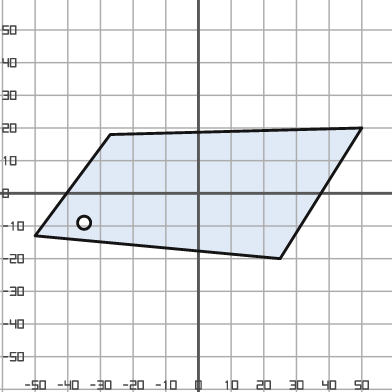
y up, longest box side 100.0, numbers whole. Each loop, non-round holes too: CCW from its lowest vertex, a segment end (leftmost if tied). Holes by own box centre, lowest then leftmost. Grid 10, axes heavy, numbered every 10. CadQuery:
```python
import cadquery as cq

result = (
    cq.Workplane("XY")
    .moveTo(25.0, -20.0)
    .lineTo(50.0, 20.0)
    .lineTo(-27.0, 18.0)
    .lineTo(-50.0, -13.0)
    .close()
    .moveTo(-35.0, -9.0)
    .circle(2.0)
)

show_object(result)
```